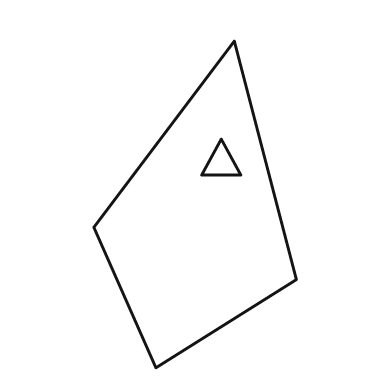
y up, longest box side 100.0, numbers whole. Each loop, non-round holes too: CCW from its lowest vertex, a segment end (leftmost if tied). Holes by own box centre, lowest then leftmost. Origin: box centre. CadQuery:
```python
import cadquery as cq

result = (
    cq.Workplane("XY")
    .moveTo(-12.0, -50.0)
    .lineTo(31.0, -23.0)
    .lineTo(12.0, 50.0)
    .lineTo(-31.0, -7.0)
    .close()
    .moveTo(2.0, 9.0)
    .lineTo(14.0, 9.0)
    .lineTo(8.0, 20.0)
    .close()
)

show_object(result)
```